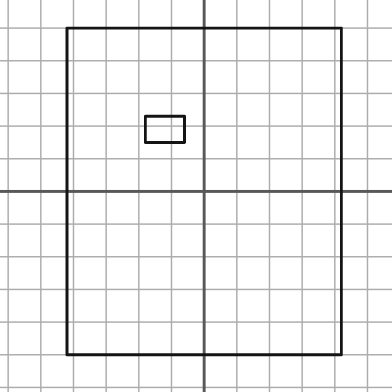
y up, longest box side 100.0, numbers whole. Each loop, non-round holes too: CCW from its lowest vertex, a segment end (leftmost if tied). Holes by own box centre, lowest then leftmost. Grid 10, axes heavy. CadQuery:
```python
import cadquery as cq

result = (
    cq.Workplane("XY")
    .moveTo(-42.0, -50.0)
    .lineTo(42.0, -50.0)
    .lineTo(42.0, 50.0)
    .lineTo(-42.0, 50.0)
    .close()
    .moveTo(-18.0, 15.0)
    .lineTo(-6.0, 15.0)
    .lineTo(-6.0, 23.0)
    .lineTo(-18.0, 23.0)
    .close()
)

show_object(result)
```